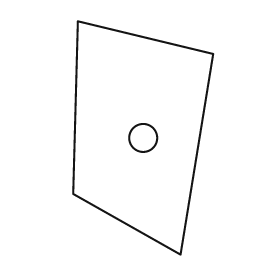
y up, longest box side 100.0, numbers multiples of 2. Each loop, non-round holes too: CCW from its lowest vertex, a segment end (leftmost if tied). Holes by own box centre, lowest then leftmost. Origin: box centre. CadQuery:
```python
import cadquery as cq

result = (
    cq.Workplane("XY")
    .moveTo(16.0, -50.0)
    .lineTo(30.0, 36.0)
    .lineTo(-28.0, 50.0)
    .lineTo(-30.0, -24.0)
    .close()
    .moveTo(0.0, 0.0)
    .circle(6.0)
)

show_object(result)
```